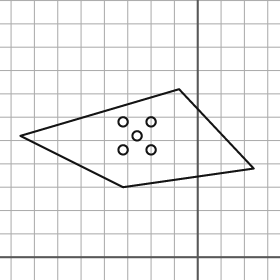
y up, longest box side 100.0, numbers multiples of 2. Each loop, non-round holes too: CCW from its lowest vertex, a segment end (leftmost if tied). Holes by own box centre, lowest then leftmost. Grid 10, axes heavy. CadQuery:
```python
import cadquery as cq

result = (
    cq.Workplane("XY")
    .moveTo(-32.0, 30.0)
    .lineTo(24.0, 38.0)
    .lineTo(-8.0, 72.0)
    .lineTo(-76.0, 52.0)
    .close()
    .moveTo(-32.0, 46.0)
    .circle(2.0)
    .moveTo(-20.0, 46.0)
    .circle(2.0)
    .moveTo(-26.0, 52.0)
    .circle(2.0)
    .moveTo(-32.0, 58.0)
    .circle(2.0)
    .moveTo(-20.0, 58.0)
    .circle(2.0)
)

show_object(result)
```